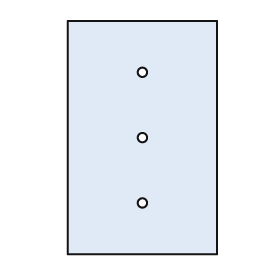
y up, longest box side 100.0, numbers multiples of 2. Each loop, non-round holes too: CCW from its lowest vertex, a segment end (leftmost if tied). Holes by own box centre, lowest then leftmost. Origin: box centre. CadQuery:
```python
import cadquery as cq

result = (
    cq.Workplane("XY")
    .moveTo(-32.0, -50.0)
    .lineTo(32.0, -50.0)
    .lineTo(32.0, 50.0)
    .lineTo(-32.0, 50.0)
    .close()
    .moveTo(0.0, -28.0)
    .circle(2.0)
    .moveTo(0.0, 0.0)
    .circle(2.0)
    .moveTo(0.0, 28.0)
    .circle(2.0)
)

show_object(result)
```